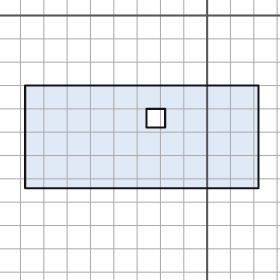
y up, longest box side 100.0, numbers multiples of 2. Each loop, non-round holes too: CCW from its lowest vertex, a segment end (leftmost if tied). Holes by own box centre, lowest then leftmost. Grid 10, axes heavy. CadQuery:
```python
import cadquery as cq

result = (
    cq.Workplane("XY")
    .moveTo(-78.0, -74.0)
    .lineTo(22.0, -74.0)
    .lineTo(22.0, -30.0)
    .lineTo(-78.0, -30.0)
    .close()
    .moveTo(-26.0, -48.0)
    .lineTo(-18.0, -48.0)
    .lineTo(-18.0, -40.0)
    .lineTo(-26.0, -40.0)
    .close()
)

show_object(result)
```